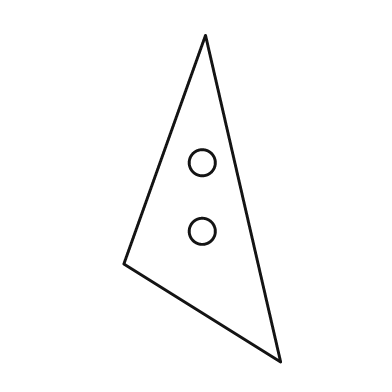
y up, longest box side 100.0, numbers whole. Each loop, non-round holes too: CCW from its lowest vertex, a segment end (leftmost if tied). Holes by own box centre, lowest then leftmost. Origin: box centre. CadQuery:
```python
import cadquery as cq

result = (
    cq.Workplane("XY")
    .moveTo(24.0, -50.0)
    .lineTo(1.0, 50.0)
    .lineTo(-24.0, -20.0)
    .close()
    .moveTo(0.0, -10.0)
    .circle(4.0)
    .moveTo(0.0, 11.0)
    .circle(4.0)
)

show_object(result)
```